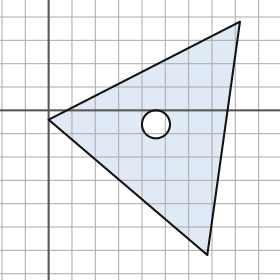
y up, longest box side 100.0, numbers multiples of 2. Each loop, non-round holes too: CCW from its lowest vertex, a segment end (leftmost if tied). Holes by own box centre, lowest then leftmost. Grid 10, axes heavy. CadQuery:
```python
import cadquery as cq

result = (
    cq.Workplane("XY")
    .moveTo(68.0, -62.0)
    .lineTo(82.0, 38.0)
    .lineTo(0.0, -4.0)
    .close()
    .moveTo(46.0, -6.0)
    .circle(6.0)
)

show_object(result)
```